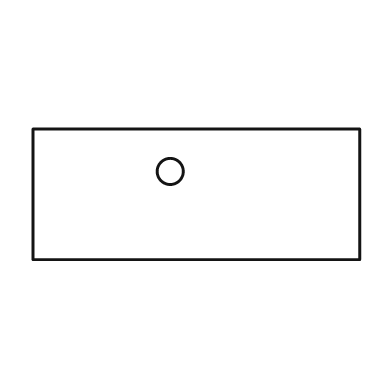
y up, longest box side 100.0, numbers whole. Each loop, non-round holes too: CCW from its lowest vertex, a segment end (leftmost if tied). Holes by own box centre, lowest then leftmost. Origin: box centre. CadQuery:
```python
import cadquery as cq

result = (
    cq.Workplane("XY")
    .moveTo(-50.0, -20.0)
    .lineTo(50.0, -20.0)
    .lineTo(50.0, 20.0)
    .lineTo(-50.0, 20.0)
    .close()
    .moveTo(-8.0, 7.0)
    .circle(4.0)
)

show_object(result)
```